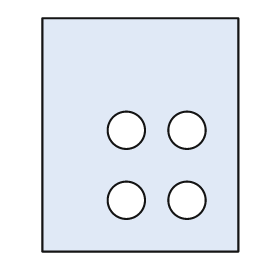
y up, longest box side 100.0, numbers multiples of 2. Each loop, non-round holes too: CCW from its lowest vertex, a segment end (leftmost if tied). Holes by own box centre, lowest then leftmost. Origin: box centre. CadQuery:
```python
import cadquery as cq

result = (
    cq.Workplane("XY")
    .moveTo(-42.0, -50.0)
    .lineTo(42.0, -50.0)
    .lineTo(42.0, 50.0)
    .lineTo(-42.0, 50.0)
    .close()
    .moveTo(-6.0, -28.0)
    .circle(8.0)
    .moveTo(20.0, -28.0)
    .circle(8.0)
    .moveTo(-6.0, 2.0)
    .circle(8.0)
    .moveTo(20.0, 2.0)
    .circle(8.0)
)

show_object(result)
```